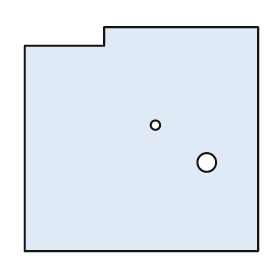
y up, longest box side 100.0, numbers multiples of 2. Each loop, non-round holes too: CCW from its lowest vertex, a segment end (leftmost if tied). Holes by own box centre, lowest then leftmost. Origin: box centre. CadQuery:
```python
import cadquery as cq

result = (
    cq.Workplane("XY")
    .moveTo(-50.0, -48.0)
    .lineTo(50.0, -48.0)
    .lineTo(50.0, 48.0)
    .lineTo(-16.0, 48.0)
    .lineTo(-16.0, 40.0)
    .lineTo(-50.0, 40.0)
    .close()
    .moveTo(28.0, -10.0)
    .circle(4.0)
    .moveTo(6.0, 6.0)
    .circle(2.0)
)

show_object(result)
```